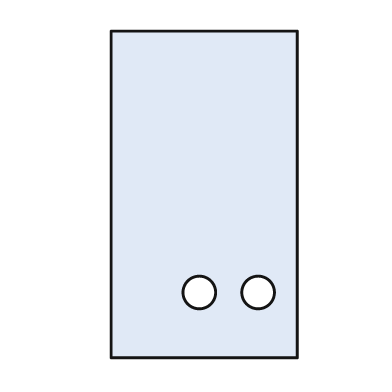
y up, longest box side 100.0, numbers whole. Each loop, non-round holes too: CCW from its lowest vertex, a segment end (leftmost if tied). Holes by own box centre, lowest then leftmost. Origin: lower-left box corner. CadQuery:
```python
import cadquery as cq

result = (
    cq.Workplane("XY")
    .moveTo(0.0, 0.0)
    .lineTo(57.0, 0.0)
    .lineTo(57.0, 100.0)
    .lineTo(0.0, 100.0)
    .close()
    .moveTo(27.0, 20.0)
    .circle(5.0)
    .moveTo(45.0, 20.0)
    .circle(5.0)
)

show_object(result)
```